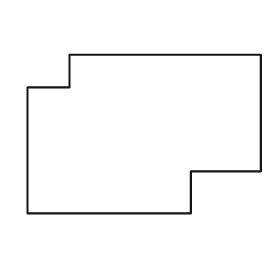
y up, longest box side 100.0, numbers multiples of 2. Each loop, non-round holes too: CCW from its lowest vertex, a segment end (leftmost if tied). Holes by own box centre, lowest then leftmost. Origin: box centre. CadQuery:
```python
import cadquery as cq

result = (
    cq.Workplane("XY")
    .moveTo(-50.0, -34.0)
    .lineTo(20.0, -34.0)
    .lineTo(20.0, -16.0)
    .lineTo(50.0, -16.0)
    .lineTo(50.0, 34.0)
    .lineTo(-32.0, 34.0)
    .lineTo(-32.0, 20.0)
    .lineTo(-50.0, 20.0)
    .close()
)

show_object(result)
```